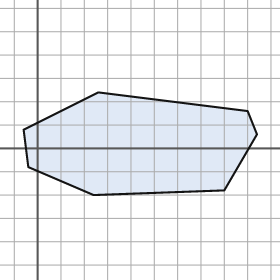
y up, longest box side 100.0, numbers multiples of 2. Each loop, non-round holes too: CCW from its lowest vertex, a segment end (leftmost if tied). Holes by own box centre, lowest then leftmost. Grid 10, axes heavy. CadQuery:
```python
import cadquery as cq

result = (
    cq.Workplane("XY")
    .moveTo(24.0, -20.0)
    .lineTo(80.0, -18.0)
    .lineTo(94.0, 6.0)
    .lineTo(90.0, 16.0)
    .lineTo(26.0, 24.0)
    .lineTo(-6.0, 8.0)
    .lineTo(-4.0, -8.0)
    .close()
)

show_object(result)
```